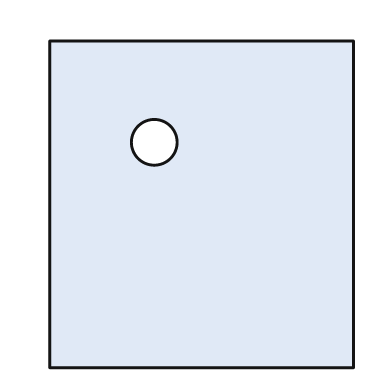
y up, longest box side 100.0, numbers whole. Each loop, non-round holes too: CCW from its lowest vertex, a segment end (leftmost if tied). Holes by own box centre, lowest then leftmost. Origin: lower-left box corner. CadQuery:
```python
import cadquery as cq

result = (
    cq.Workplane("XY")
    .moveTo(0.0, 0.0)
    .lineTo(93.0, 0.0)
    .lineTo(93.0, 100.0)
    .lineTo(0.0, 100.0)
    .close()
    .moveTo(32.0, 69.0)
    .circle(7.0)
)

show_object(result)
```